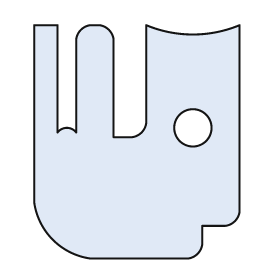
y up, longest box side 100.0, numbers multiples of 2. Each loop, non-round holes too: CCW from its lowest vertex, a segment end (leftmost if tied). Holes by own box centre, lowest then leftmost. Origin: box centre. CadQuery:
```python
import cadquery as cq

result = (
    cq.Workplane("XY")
    .moveTo(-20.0, -50.0)
    .lineTo(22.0, -50.0)
    .threePointArc((26.0, -48.0), (28.0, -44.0))
    .lineTo(28.0, -36.0)
    .lineTo(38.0, -36.0)
    .threePointArc((42.0, -34.0), (44.0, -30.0))
    .lineTo(44.0, 50.0)
    .threePointArc((24.0, 46.0), (4.0, 50.0))
    .lineTo(4.0, 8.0)
    .threePointArc((2.0, 4.0), (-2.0, 2.0))
    .lineTo(-10.0, 2.0)
    .lineTo(-10.0, 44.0)
    .threePointArc((-12.0, 48.0), (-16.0, 50.0))
    .lineTo(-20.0, 50.0)
    .threePointArc((-24.0, 48.0), (-26.0, 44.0))
    .lineTo(-26.0, 4.0)
    .threePointArc((-30.0, 6.0), (-34.0, 4.0))
    .lineTo(-34.0, 50.0)
    .lineTo(-44.0, 50.0)
    .lineTo(-44.0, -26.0)
    .threePointArc((-36.0, -42.0), (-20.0, -50.0))
    .close()
    .moveTo(24.0, 6.0)
    .circle(8.0)
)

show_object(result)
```